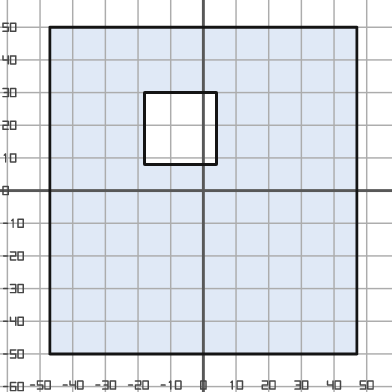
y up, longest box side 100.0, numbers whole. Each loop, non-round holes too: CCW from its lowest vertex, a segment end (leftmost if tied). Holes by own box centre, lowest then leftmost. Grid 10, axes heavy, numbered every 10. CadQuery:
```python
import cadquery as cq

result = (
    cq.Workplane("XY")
    .moveTo(-47.0, -50.0)
    .lineTo(47.0, -50.0)
    .lineTo(47.0, 50.0)
    .lineTo(-47.0, 50.0)
    .close()
    .moveTo(-18.0, 8.0)
    .lineTo(4.0, 8.0)
    .lineTo(4.0, 30.0)
    .lineTo(-18.0, 30.0)
    .close()
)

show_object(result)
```